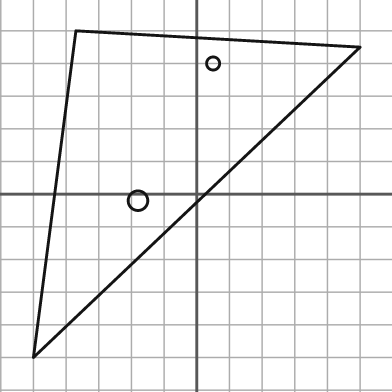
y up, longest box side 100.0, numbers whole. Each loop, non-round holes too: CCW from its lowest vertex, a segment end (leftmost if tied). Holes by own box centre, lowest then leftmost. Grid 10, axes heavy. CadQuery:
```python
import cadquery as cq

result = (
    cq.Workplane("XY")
    .moveTo(-50.0, -50.0)
    .lineTo(50.0, 45.0)
    .lineTo(-37.0, 50.0)
    .close()
    .moveTo(-18.0, -2.0)
    .circle(3.0)
    .moveTo(5.0, 40.0)
    .circle(2.0)
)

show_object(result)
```